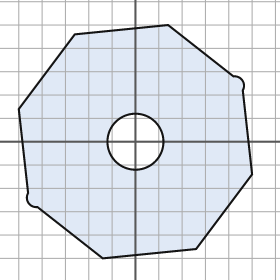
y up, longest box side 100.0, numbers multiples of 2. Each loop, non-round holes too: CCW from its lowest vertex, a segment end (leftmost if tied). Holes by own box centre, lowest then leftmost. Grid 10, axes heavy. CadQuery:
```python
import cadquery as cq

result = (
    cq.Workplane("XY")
    .moveTo(-14.0, -50.0)
    .lineTo(26.0, -46.0)
    .lineTo(50.0, -14.0)
    .lineTo(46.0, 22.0)
    .threePointArc((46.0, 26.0), (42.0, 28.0))
    .lineTo(14.0, 50.0)
    .lineTo(-26.0, 46.0)
    .lineTo(-50.0, 14.0)
    .lineTo(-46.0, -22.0)
    .threePointArc((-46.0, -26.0), (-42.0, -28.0))
    .close()
    .moveTo(0.0, 0.0)
    .circle(12.0)
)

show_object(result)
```